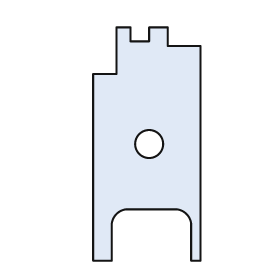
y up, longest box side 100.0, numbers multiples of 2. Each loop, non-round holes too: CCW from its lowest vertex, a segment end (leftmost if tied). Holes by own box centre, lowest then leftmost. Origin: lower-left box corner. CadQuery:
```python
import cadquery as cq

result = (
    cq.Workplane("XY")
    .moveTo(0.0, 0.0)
    .lineTo(8.0, 0.0)
    .lineTo(8.0, 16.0)
    .threePointArc((10.0, 20.0), (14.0, 22.0))
    .lineTo(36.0, 22.0)
    .threePointArc((40.0, 20.0), (42.0, 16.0))
    .lineTo(42.0, 0.0)
    .lineTo(46.0, 0.0)
    .lineTo(46.0, 92.0)
    .lineTo(32.0, 92.0)
    .lineTo(32.0, 100.0)
    .lineTo(24.0, 100.0)
    .lineTo(24.0, 94.0)
    .lineTo(16.0, 94.0)
    .lineTo(16.0, 100.0)
    .lineTo(10.0, 100.0)
    .lineTo(10.0, 80.0)
    .lineTo(0.0, 80.0)
    .close()
    .moveTo(24.0, 50.0)
    .circle(6.0)
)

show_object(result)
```